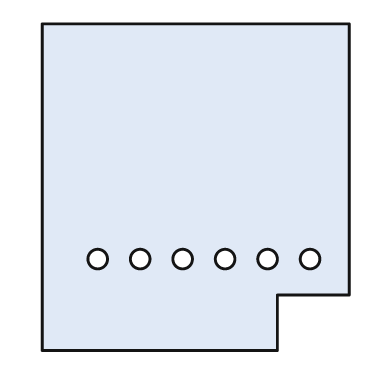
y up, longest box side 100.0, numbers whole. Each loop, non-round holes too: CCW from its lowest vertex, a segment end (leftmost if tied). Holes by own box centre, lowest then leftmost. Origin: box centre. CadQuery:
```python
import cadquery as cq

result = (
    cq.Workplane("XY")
    .moveTo(-47.0, -50.0)
    .lineTo(25.0, -50.0)
    .lineTo(25.0, -33.0)
    .lineTo(47.0, -33.0)
    .lineTo(47.0, 50.0)
    .lineTo(-47.0, 50.0)
    .close()
    .moveTo(-30.0, -22.0)
    .circle(3.0)
    .moveTo(-17.0, -22.0)
    .circle(3.0)
    .moveTo(-4.0, -22.0)
    .circle(3.0)
    .moveTo(9.0, -22.0)
    .circle(3.0)
    .moveTo(22.0, -22.0)
    .circle(3.0)
    .moveTo(35.0, -22.0)
    .circle(3.0)
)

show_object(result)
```